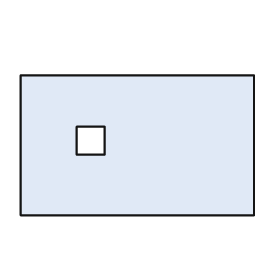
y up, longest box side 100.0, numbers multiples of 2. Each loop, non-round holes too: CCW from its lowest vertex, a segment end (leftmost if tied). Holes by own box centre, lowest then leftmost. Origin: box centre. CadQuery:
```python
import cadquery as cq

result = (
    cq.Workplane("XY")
    .moveTo(-50.0, -30.0)
    .lineTo(50.0, -30.0)
    .lineTo(50.0, 30.0)
    .lineTo(-50.0, 30.0)
    .close()
    .moveTo(-26.0, -4.0)
    .lineTo(-14.0, -4.0)
    .lineTo(-14.0, 8.0)
    .lineTo(-26.0, 8.0)
    .close()
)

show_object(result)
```